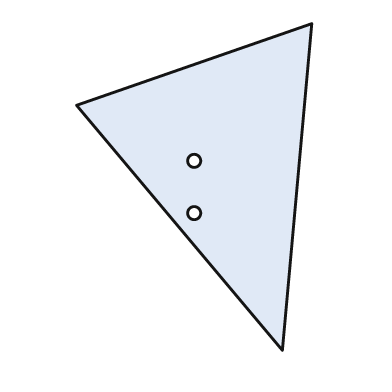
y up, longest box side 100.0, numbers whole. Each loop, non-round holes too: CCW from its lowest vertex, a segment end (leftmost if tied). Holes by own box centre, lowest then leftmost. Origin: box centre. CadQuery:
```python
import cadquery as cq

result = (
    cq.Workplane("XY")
    .moveTo(27.0, -50.0)
    .lineTo(36.0, 50.0)
    .lineTo(-36.0, 25.0)
    .close()
    .moveTo(0.0, -8.0)
    .circle(2.0)
    .moveTo(0.0, 8.0)
    .circle(2.0)
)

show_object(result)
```